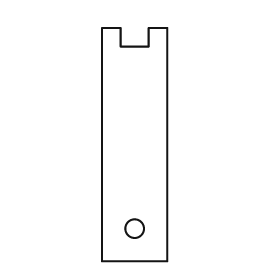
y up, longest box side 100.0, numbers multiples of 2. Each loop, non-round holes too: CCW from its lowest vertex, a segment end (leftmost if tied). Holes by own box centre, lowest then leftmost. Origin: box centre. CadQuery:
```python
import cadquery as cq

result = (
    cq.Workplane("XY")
    .moveTo(-14.0, -50.0)
    .lineTo(14.0, -50.0)
    .lineTo(14.0, 50.0)
    .lineTo(6.0, 50.0)
    .lineTo(6.0, 42.0)
    .lineTo(-6.0, 42.0)
    .lineTo(-6.0, 50.0)
    .lineTo(-14.0, 50.0)
    .close()
    .moveTo(0.0, -36.0)
    .circle(4.0)
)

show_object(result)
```